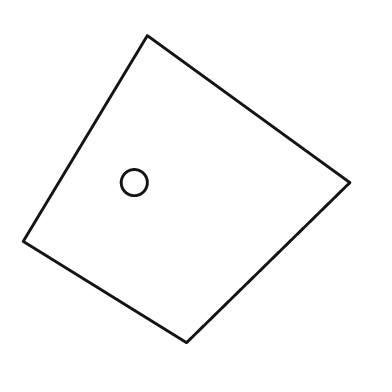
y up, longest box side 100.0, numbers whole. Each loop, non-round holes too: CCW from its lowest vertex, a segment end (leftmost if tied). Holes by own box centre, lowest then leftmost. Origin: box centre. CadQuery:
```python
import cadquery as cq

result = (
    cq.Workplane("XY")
    .moveTo(0.0, -47.0)
    .lineTo(50.0, 2.0)
    .lineTo(-12.0, 47.0)
    .lineTo(-50.0, -16.0)
    .close()
    .moveTo(-16.0, 2.0)
    .circle(4.0)
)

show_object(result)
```